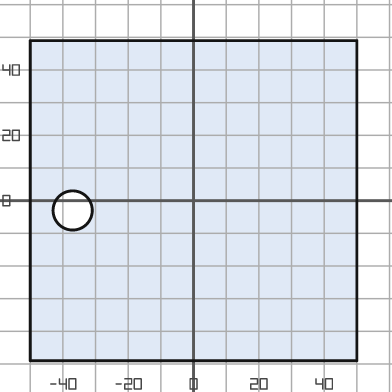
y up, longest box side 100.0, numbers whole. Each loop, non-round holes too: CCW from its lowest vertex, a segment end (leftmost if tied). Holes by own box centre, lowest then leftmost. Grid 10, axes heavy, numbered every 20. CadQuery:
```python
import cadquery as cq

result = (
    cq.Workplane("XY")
    .moveTo(-50.0, -49.0)
    .lineTo(50.0, -49.0)
    .lineTo(50.0, 49.0)
    .lineTo(-50.0, 49.0)
    .close()
    .moveTo(-37.0, -3.0)
    .circle(6.0)
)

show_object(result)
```